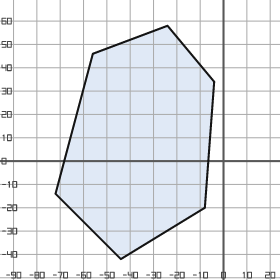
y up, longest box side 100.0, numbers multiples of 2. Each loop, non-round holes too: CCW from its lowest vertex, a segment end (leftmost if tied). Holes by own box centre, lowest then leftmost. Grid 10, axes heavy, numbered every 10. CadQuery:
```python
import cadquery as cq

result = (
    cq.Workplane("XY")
    .moveTo(-44.0, -42.0)
    .lineTo(-8.0, -20.0)
    .lineTo(-4.0, 34.0)
    .lineTo(-24.0, 58.0)
    .lineTo(-56.0, 46.0)
    .lineTo(-72.0, -14.0)
    .close()
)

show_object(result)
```